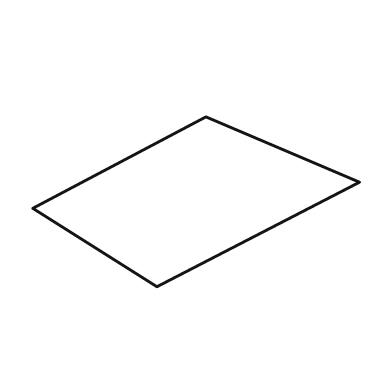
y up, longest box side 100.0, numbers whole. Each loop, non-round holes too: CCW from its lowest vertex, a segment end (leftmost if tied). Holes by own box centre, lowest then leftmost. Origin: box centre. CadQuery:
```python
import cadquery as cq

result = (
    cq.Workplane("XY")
    .moveTo(-12.0, -26.0)
    .lineTo(50.0, 6.0)
    .lineTo(3.0, 26.0)
    .lineTo(-50.0, -2.0)
    .close()
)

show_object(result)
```